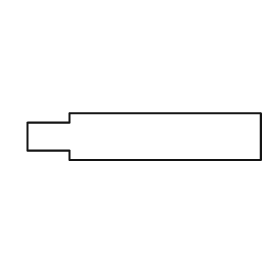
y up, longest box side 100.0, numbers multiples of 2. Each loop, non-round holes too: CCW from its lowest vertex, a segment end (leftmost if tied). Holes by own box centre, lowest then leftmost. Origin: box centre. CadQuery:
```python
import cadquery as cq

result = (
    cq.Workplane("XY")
    .moveTo(-32.0, -10.0)
    .lineTo(50.0, -10.0)
    .lineTo(50.0, 10.0)
    .lineTo(-32.0, 10.0)
    .lineTo(-32.0, 6.0)
    .lineTo(-50.0, 6.0)
    .lineTo(-50.0, -6.0)
    .lineTo(-32.0, -6.0)
    .close()
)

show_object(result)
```